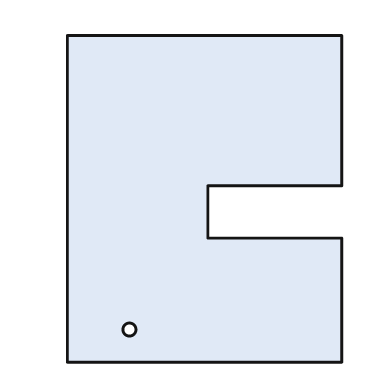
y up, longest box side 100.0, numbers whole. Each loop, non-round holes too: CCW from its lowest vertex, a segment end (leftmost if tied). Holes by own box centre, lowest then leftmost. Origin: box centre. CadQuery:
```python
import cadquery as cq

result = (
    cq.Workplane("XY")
    .moveTo(-42.0, -50.0)
    .lineTo(42.0, -50.0)
    .lineTo(42.0, -12.0)
    .lineTo(1.0, -12.0)
    .lineTo(1.0, 4.0)
    .lineTo(42.0, 4.0)
    .lineTo(42.0, 50.0)
    .lineTo(-42.0, 50.0)
    .close()
    .moveTo(-23.0, -40.0)
    .circle(2.0)
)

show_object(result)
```